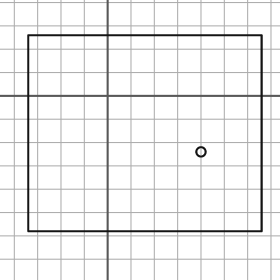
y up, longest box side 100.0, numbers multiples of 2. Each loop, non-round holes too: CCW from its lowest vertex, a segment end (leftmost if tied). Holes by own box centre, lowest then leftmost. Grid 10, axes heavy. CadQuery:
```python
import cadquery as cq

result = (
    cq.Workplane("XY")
    .moveTo(-34.0, -58.0)
    .lineTo(66.0, -58.0)
    .lineTo(66.0, 26.0)
    .lineTo(-34.0, 26.0)
    .close()
    .moveTo(40.0, -24.0)
    .circle(2.0)
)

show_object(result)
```